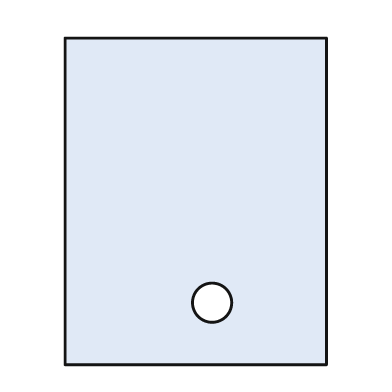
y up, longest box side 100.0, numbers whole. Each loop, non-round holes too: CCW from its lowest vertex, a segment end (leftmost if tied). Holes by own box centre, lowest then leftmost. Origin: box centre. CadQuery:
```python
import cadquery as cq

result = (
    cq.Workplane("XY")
    .moveTo(-40.0, -50.0)
    .lineTo(40.0, -50.0)
    .lineTo(40.0, 50.0)
    .lineTo(-40.0, 50.0)
    .close()
    .moveTo(5.0, -31.0)
    .circle(6.0)
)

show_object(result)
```